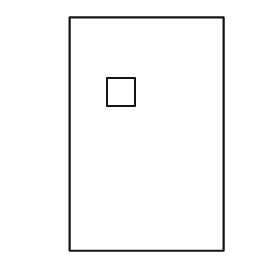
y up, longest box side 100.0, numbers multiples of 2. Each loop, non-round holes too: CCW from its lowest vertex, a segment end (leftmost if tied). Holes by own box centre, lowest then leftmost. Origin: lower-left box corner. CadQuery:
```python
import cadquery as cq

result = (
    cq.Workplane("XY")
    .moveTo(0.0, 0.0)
    .lineTo(66.0, 0.0)
    .lineTo(66.0, 100.0)
    .lineTo(0.0, 100.0)
    .close()
    .moveTo(16.0, 62.0)
    .lineTo(28.0, 62.0)
    .lineTo(28.0, 74.0)
    .lineTo(16.0, 74.0)
    .close()
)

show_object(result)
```